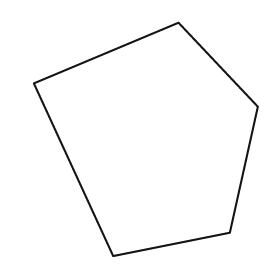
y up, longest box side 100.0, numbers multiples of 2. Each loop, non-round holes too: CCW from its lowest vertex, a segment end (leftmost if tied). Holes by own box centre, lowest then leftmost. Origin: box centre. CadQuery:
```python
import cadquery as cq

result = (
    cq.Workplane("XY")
    .moveTo(-14.0, -50.0)
    .lineTo(36.0, -40.0)
    .lineTo(48.0, 14.0)
    .lineTo(14.0, 50.0)
    .lineTo(-48.0, 24.0)
    .close()
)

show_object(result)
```